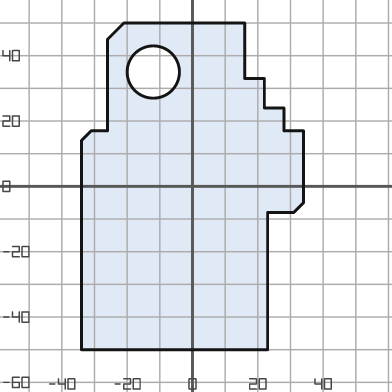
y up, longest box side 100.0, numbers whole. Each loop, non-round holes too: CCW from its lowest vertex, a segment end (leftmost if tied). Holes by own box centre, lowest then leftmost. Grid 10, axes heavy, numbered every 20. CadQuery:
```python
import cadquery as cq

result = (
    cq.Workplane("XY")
    .moveTo(-34.0, -50.0)
    .lineTo(23.0, -50.0)
    .lineTo(23.0, -8.0)
    .lineTo(31.0, -8.0)
    .lineTo(34.0, -5.0)
    .lineTo(34.0, 17.0)
    .lineTo(28.0, 17.0)
    .lineTo(28.0, 24.0)
    .lineTo(22.0, 24.0)
    .lineTo(22.0, 33.0)
    .lineTo(16.0, 33.0)
    .lineTo(16.0, 50.0)
    .lineTo(-21.0, 50.0)
    .lineTo(-26.0, 45.0)
    .lineTo(-26.0, 17.0)
    .lineTo(-31.0, 17.0)
    .lineTo(-34.0, 14.0)
    .close()
    .moveTo(-12.0, 35.0)
    .circle(8.0)
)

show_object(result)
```